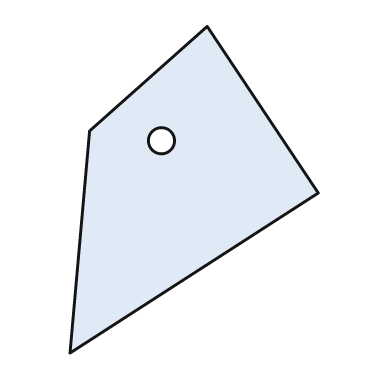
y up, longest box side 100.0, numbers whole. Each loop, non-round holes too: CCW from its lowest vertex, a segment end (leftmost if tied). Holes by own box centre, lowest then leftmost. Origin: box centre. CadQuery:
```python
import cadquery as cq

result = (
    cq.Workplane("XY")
    .moveTo(-38.0, -50.0)
    .lineTo(38.0, -1.0)
    .lineTo(4.0, 50.0)
    .lineTo(-32.0, 18.0)
    .close()
    .moveTo(-10.0, 15.0)
    .circle(4.0)
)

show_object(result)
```